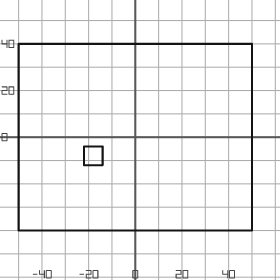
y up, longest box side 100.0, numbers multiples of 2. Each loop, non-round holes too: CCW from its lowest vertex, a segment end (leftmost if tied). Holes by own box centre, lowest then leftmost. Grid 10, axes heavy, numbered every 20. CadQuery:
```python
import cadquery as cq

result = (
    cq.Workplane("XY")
    .moveTo(-50.0, -40.0)
    .lineTo(50.0, -40.0)
    .lineTo(50.0, 40.0)
    .lineTo(-50.0, 40.0)
    .close()
    .moveTo(-22.0, -12.0)
    .lineTo(-14.0, -12.0)
    .lineTo(-14.0, -4.0)
    .lineTo(-22.0, -4.0)
    .close()
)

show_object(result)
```